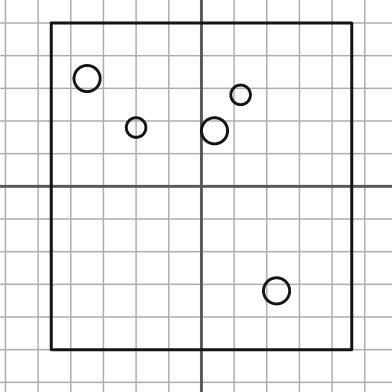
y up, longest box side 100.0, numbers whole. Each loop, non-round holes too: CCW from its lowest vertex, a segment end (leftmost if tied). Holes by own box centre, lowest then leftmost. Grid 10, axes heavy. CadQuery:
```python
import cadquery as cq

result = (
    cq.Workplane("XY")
    .moveTo(-46.0, -50.0)
    .lineTo(46.0, -50.0)
    .lineTo(46.0, 50.0)
    .lineTo(-46.0, 50.0)
    .close()
    .moveTo(23.0, -32.0)
    .circle(4.0)
    .moveTo(4.0, 17.0)
    .circle(4.0)
    .moveTo(-20.0, 18.0)
    .circle(3.0)
    .moveTo(12.0, 28.0)
    .circle(3.0)
    .moveTo(-35.0, 33.0)
    .circle(4.0)
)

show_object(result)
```